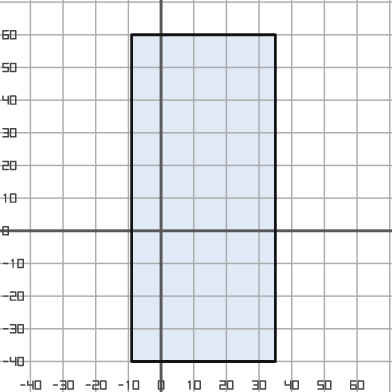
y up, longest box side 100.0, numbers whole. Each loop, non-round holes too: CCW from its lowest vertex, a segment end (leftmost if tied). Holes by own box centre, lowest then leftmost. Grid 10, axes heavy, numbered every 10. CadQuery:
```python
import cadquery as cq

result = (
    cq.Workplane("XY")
    .moveTo(-9.0, -40.0)
    .lineTo(35.0, -40.0)
    .lineTo(35.0, 60.0)
    .lineTo(-9.0, 60.0)
    .close()
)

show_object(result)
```